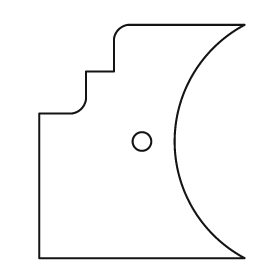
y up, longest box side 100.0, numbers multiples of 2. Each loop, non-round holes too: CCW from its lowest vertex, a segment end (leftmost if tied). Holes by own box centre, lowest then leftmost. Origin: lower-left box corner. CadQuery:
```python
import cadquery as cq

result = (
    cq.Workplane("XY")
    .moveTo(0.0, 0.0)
    .lineTo(88.0, 0.0)
    .threePointArc((58.0, 50.0), (88.0, 100.0))
    .lineTo(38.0, 100.0)
    .threePointArc((34.0, 98.0), (32.0, 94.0))
    .lineTo(32.0, 80.0)
    .lineTo(20.0, 80.0)
    .lineTo(20.0, 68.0)
    .threePointArc((18.0, 64.0), (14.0, 62.0))
    .lineTo(0.0, 62.0)
    .close()
    .moveTo(44.0, 50.0)
    .circle(4.0)
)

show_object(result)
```